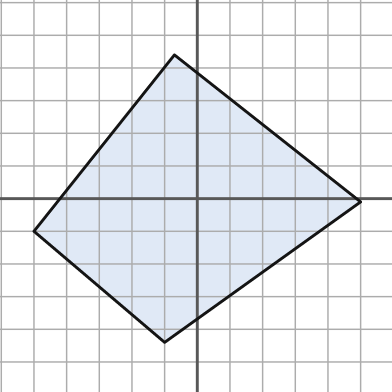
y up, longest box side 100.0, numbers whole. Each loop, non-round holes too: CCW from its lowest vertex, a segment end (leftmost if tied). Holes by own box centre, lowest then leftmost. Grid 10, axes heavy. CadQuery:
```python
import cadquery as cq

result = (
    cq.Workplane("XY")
    .moveTo(-10.0, -44.0)
    .lineTo(50.0, -1.0)
    .lineTo(-7.0, 44.0)
    .lineTo(-50.0, -10.0)
    .close()
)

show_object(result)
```